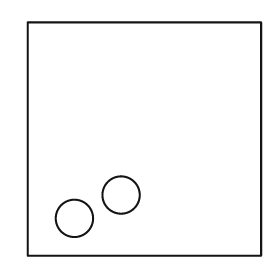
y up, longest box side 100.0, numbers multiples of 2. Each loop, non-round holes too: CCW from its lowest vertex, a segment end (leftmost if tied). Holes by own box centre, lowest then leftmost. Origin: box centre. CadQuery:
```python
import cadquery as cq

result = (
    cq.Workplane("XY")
    .moveTo(-50.0, -50.0)
    .lineTo(50.0, -50.0)
    .lineTo(50.0, 50.0)
    .lineTo(-50.0, 50.0)
    .close()
    .moveTo(-30.0, -34.0)
    .circle(8.0)
    .moveTo(-10.0, -24.0)
    .circle(8.0)
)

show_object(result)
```